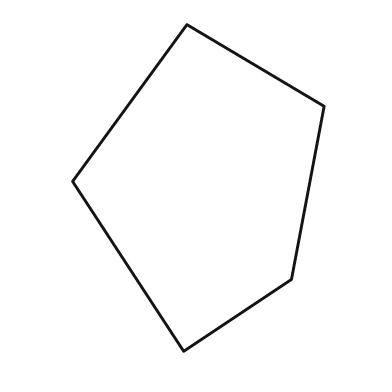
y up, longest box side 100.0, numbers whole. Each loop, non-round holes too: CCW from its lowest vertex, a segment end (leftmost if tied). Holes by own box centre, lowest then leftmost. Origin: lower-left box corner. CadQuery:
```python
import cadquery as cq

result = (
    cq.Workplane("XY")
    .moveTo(34.0, 0.0)
    .lineTo(67.0, 22.0)
    .lineTo(77.0, 75.0)
    .lineTo(35.0, 100.0)
    .lineTo(0.0, 52.0)
    .close()
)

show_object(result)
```